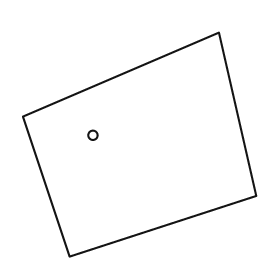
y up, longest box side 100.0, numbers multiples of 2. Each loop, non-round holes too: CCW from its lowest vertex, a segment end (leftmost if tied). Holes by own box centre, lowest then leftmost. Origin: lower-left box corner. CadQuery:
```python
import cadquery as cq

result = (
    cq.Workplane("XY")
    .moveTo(20.0, 0.0)
    .lineTo(100.0, 26.0)
    .lineTo(84.0, 96.0)
    .lineTo(0.0, 60.0)
    .close()
    .moveTo(30.0, 52.0)
    .circle(2.0)
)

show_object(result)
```